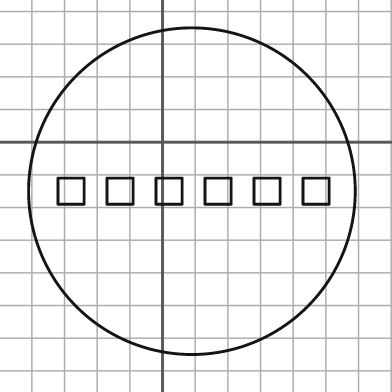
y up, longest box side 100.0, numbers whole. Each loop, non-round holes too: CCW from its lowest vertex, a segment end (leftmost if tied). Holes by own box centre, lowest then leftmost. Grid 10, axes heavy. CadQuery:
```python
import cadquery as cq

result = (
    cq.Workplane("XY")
    .moveTo(9.0, -15.0)
    .circle(50.0)
    .moveTo(-32.0, -19.0)
    .lineTo(-24.0, -19.0)
    .lineTo(-24.0, -11.0)
    .lineTo(-32.0, -11.0)
    .close()
    .moveTo(-17.0, -19.0)
    .lineTo(-9.0, -19.0)
    .lineTo(-9.0, -11.0)
    .lineTo(-17.0, -11.0)
    .close()
    .moveTo(-2.0, -19.0)
    .lineTo(6.0, -19.0)
    .lineTo(6.0, -11.0)
    .lineTo(-2.0, -11.0)
    .close()
    .moveTo(13.0, -19.0)
    .lineTo(21.0, -19.0)
    .lineTo(21.0, -11.0)
    .lineTo(13.0, -11.0)
    .close()
    .moveTo(28.0, -19.0)
    .lineTo(36.0, -19.0)
    .lineTo(36.0, -11.0)
    .lineTo(28.0, -11.0)
    .close()
    .moveTo(43.0, -19.0)
    .lineTo(51.0, -19.0)
    .lineTo(51.0, -11.0)
    .lineTo(43.0, -11.0)
    .close()
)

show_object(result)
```